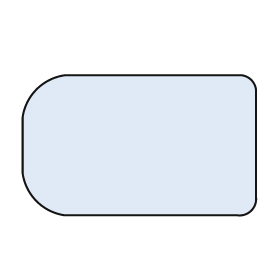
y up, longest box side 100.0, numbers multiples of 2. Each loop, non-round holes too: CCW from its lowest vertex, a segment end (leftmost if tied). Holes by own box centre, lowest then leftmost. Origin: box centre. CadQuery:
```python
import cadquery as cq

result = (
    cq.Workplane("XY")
    .moveTo(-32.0, -30.0)
    .lineTo(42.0, -30.0)
    .threePointArc((48.0, -28.0), (50.0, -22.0))
    .lineTo(50.0, 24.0)
    .threePointArc((48.0, 28.0), (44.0, 30.0))
    .lineTo(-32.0, 30.0)
    .threePointArc((-44.0, 24.0), (-50.0, 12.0))
    .lineTo(-50.0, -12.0)
    .threePointArc((-44.0, -24.0), (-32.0, -30.0))
    .close()
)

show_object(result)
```